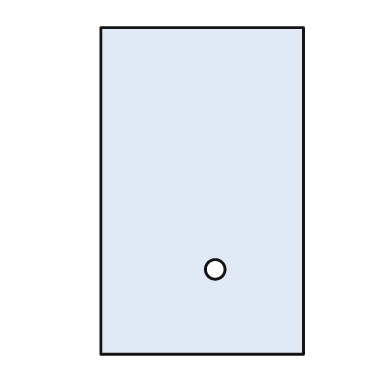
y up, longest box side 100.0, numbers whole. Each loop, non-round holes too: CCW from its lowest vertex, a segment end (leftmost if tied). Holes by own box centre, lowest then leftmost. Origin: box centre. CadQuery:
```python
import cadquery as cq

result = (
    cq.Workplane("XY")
    .moveTo(-31.0, -50.0)
    .lineTo(31.0, -50.0)
    .lineTo(31.0, 50.0)
    .lineTo(-31.0, 50.0)
    .close()
    .moveTo(4.0, -24.0)
    .circle(3.0)
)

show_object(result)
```